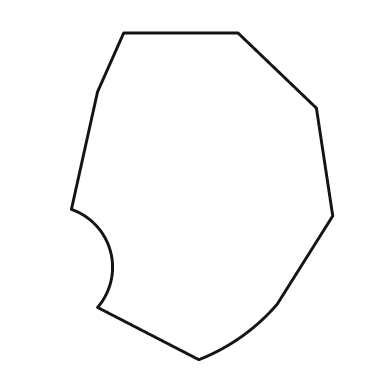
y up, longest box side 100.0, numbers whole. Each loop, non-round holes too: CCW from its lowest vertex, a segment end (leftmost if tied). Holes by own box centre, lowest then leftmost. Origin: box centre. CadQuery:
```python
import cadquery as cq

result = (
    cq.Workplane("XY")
    .moveTo(-1.0, -50.0)
    .threePointArc((12.0, -43.0), (23.0, -33.0))
    .lineTo(40.0, -6.0)
    .lineTo(35.0, 27.0)
    .lineTo(11.0, 50.0)
    .lineTo(-24.0, 50.0)
    .lineTo(-32.0, 32.0)
    .lineTo(-40.0, -4.0)
    .threePointArc((-28.0, -17.0), (-32.0, -34.0))
    .close()
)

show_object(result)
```